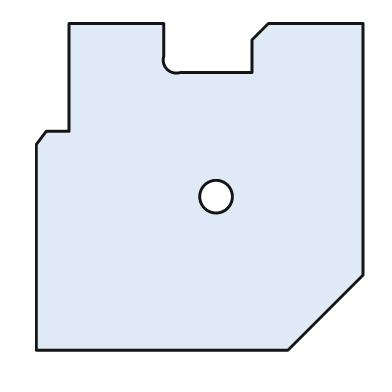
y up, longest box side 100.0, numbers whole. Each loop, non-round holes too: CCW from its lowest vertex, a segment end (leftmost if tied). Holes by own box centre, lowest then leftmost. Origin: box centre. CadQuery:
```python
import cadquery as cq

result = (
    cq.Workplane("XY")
    .moveTo(-50.0, -50.0)
    .lineTo(27.0, -50.0)
    .lineTo(50.0, -27.0)
    .lineTo(50.0, 50.0)
    .lineTo(21.0, 50.0)
    .lineTo(16.0, 45.0)
    .lineTo(16.0, 35.0)
    .lineTo(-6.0, 35.0)
    .threePointArc((-10.0, 36.0), (-11.0, 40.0))
    .lineTo(-11.0, 50.0)
    .lineTo(-40.0, 50.0)
    .lineTo(-40.0, 17.0)
    .lineTo(-47.0, 17.0)
    .lineTo(-50.0, 13.0)
    .close()
    .moveTo(5.0, -3.0)
    .circle(5.0)
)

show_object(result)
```